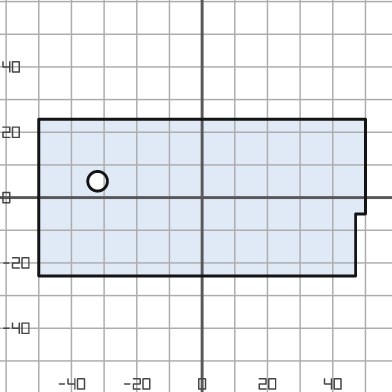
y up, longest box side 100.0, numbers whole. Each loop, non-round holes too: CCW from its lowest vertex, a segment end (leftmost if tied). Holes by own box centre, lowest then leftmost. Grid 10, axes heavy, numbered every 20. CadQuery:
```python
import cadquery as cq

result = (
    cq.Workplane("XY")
    .moveTo(-50.0, -24.0)
    .lineTo(47.0, -24.0)
    .lineTo(47.0, -5.0)
    .lineTo(50.0, -5.0)
    .lineTo(50.0, 24.0)
    .lineTo(-50.0, 24.0)
    .close()
    .moveTo(-32.0, 5.0)
    .circle(3.0)
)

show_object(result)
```